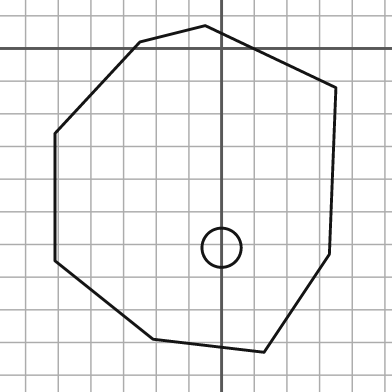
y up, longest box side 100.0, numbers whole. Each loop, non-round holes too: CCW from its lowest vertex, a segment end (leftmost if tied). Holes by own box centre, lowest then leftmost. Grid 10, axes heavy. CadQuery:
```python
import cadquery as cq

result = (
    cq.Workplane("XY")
    .moveTo(13.0, -93.0)
    .lineTo(33.0, -63.0)
    .lineTo(35.0, -12.0)
    .lineTo(-5.0, 7.0)
    .lineTo(-25.0, 2.0)
    .lineTo(-51.0, -26.0)
    .lineTo(-51.0, -65.0)
    .lineTo(-21.0, -89.0)
    .close()
    .moveTo(0.0, -61.0)
    .circle(6.0)
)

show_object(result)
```